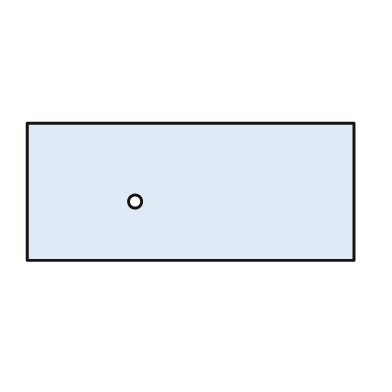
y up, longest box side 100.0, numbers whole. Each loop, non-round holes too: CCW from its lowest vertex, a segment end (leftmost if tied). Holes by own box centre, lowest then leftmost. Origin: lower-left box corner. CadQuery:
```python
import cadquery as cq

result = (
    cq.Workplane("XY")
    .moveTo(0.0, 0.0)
    .lineTo(100.0, 0.0)
    .lineTo(100.0, 42.0)
    .lineTo(0.0, 42.0)
    .close()
    .moveTo(33.0, 18.0)
    .circle(2.0)
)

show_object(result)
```